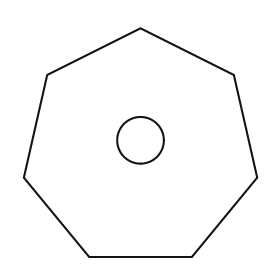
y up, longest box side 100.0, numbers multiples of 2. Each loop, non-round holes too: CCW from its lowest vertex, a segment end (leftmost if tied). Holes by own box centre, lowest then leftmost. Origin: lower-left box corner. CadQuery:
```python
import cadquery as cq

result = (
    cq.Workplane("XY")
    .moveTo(28.0, 0.0)
    .lineTo(72.0, 0.0)
    .lineTo(100.0, 34.0)
    .lineTo(90.0, 78.0)
    .lineTo(50.0, 98.0)
    .lineTo(10.0, 78.0)
    .lineTo(0.0, 34.0)
    .close()
    .moveTo(50.0, 50.0)
    .circle(10.0)
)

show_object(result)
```